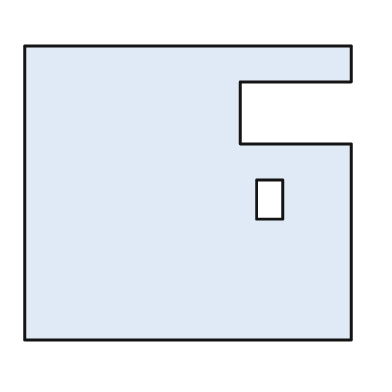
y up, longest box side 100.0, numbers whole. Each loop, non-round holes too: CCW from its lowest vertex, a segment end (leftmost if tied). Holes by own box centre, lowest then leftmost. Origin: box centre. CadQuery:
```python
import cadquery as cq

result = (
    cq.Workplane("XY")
    .moveTo(-50.0, -45.0)
    .lineTo(50.0, -45.0)
    .lineTo(50.0, 15.0)
    .lineTo(16.0, 15.0)
    .lineTo(16.0, 34.0)
    .lineTo(50.0, 34.0)
    .lineTo(50.0, 45.0)
    .lineTo(-50.0, 45.0)
    .close()
    .moveTo(21.0, -8.0)
    .lineTo(29.0, -8.0)
    .lineTo(29.0, 4.0)
    .lineTo(21.0, 4.0)
    .close()
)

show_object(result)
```